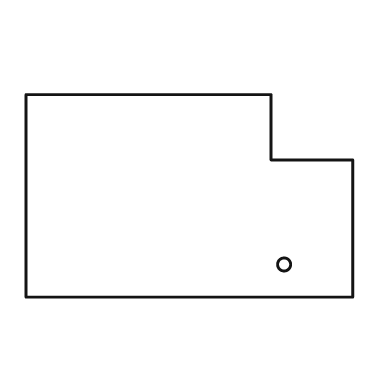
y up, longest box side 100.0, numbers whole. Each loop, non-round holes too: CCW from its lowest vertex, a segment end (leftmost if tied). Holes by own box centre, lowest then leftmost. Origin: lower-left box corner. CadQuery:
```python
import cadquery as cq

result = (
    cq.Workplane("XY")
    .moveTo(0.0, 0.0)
    .lineTo(100.0, 0.0)
    .lineTo(100.0, 42.0)
    .lineTo(75.0, 42.0)
    .lineTo(75.0, 62.0)
    .lineTo(0.0, 62.0)
    .close()
    .moveTo(79.0, 10.0)
    .circle(2.0)
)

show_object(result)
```